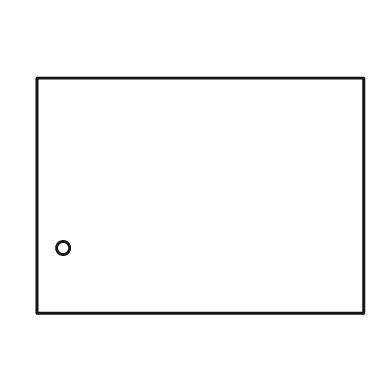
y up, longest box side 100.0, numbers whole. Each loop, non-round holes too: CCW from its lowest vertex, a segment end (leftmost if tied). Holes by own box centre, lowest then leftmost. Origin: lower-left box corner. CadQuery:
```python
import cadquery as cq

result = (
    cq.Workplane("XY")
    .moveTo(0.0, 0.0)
    .lineTo(100.0, 0.0)
    .lineTo(100.0, 72.0)
    .lineTo(0.0, 72.0)
    .close()
    .moveTo(8.0, 20.0)
    .circle(2.0)
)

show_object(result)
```